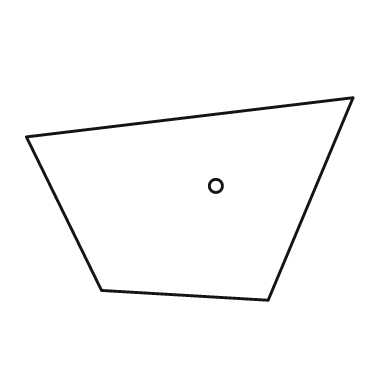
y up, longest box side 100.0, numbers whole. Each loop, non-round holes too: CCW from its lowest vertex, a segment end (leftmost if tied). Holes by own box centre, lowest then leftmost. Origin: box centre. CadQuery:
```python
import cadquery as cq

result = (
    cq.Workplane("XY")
    .moveTo(24.0, -31.0)
    .lineTo(50.0, 31.0)
    .lineTo(-50.0, 19.0)
    .lineTo(-27.0, -28.0)
    .close()
    .moveTo(8.0, 4.0)
    .circle(2.0)
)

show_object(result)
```